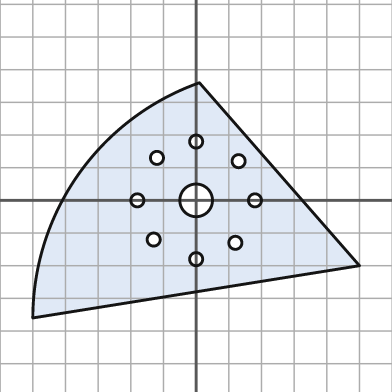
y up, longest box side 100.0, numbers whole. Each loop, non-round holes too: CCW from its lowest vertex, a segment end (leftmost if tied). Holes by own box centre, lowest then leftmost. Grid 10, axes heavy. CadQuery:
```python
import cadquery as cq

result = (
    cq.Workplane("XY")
    .moveTo(-50.0, -36.0)
    .lineTo(50.0, -20.0)
    .lineTo(1.0, 36.0)
    .threePointArc((-36.0, 8.0), (-50.0, -36.0))
    .close()
    .moveTo(0.0, -18.0)
    .circle(2.0)
    .moveTo(12.0, -13.0)
    .circle(2.0)
    .moveTo(-13.0, -12.0)
    .circle(2.0)
    .moveTo(-18.0, 0.0)
    .circle(2.0)
    .moveTo(0.0, 0.0)
    .circle(5.0)
    .moveTo(18.0, 0.0)
    .circle(2.0)
    .moveTo(13.0, 12.0)
    .circle(2.0)
    .moveTo(-12.0, 13.0)
    .circle(2.0)
    .moveTo(0.0, 18.0)
    .circle(2.0)
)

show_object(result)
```